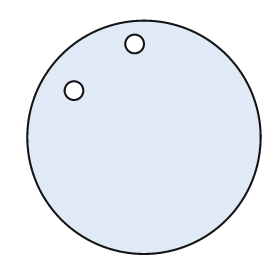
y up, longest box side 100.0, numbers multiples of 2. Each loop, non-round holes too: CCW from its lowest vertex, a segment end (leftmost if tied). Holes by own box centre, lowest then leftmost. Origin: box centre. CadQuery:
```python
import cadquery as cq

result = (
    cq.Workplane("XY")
    .moveTo(0.0, 0.0)
    .circle(50.0)
    .moveTo(-30.0, 20.0)
    .circle(4.0)
    .moveTo(-4.0, 40.0)
    .circle(4.0)
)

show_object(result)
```